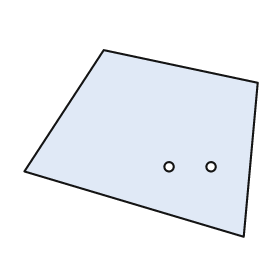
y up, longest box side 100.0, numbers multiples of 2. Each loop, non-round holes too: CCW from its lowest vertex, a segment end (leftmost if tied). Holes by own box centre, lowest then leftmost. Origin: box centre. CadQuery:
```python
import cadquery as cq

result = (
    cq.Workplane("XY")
    .moveTo(44.0, -40.0)
    .lineTo(50.0, 26.0)
    .lineTo(-16.0, 40.0)
    .lineTo(-50.0, -12.0)
    .close()
    .moveTo(12.0, -10.0)
    .circle(2.0)
    .moveTo(30.0, -10.0)
    .circle(2.0)
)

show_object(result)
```